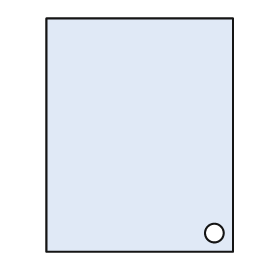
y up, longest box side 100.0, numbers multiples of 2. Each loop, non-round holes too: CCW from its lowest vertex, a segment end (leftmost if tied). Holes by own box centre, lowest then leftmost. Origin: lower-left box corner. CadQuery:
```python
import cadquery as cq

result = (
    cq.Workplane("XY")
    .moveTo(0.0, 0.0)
    .lineTo(80.0, 0.0)
    .lineTo(80.0, 100.0)
    .lineTo(0.0, 100.0)
    .close()
    .moveTo(72.0, 8.0)
    .circle(4.0)
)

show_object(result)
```